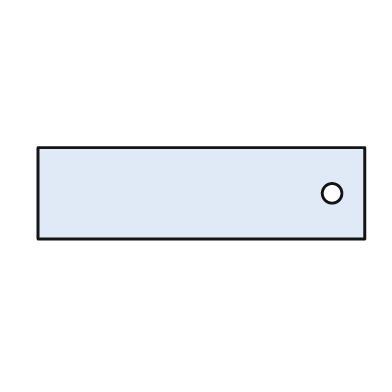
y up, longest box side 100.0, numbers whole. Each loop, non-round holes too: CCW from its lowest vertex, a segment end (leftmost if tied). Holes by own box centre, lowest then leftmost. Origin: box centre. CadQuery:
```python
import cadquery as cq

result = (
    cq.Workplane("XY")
    .moveTo(-50.0, -14.0)
    .lineTo(50.0, -14.0)
    .lineTo(50.0, 14.0)
    .lineTo(-50.0, 14.0)
    .close()
    .moveTo(40.0, 0.0)
    .circle(3.0)
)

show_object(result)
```